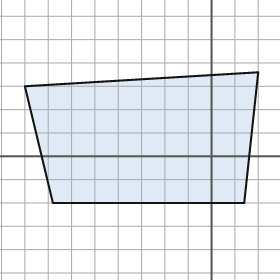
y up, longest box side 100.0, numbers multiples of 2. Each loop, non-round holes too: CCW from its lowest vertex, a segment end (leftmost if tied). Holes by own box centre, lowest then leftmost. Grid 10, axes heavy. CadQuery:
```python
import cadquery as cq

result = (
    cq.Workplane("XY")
    .moveTo(-68.0, -20.0)
    .lineTo(14.0, -20.0)
    .lineTo(20.0, 36.0)
    .lineTo(-80.0, 30.0)
    .close()
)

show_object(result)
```